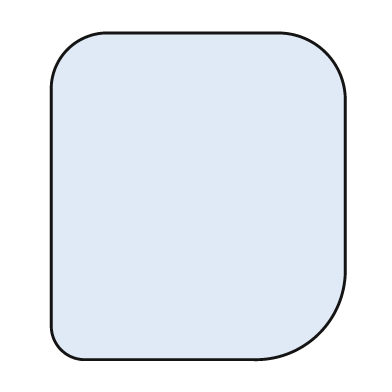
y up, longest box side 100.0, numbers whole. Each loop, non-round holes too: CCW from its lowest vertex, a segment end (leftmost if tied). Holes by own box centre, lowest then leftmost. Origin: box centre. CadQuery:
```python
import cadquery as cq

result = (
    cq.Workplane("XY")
    .moveTo(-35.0, -50.0)
    .lineTo(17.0, -50.0)
    .threePointArc((37.0, -42.0), (45.0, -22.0))
    .lineTo(45.0, 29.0)
    .threePointArc((39.0, 44.0), (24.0, 50.0))
    .lineTo(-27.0, 50.0)
    .threePointArc((-40.0, 45.0), (-45.0, 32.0))
    .lineTo(-45.0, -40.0)
    .threePointArc((-42.0, -47.0), (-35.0, -50.0))
    .close()
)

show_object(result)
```